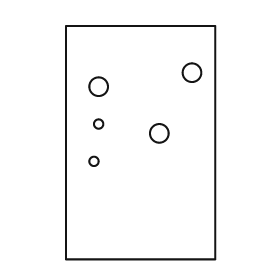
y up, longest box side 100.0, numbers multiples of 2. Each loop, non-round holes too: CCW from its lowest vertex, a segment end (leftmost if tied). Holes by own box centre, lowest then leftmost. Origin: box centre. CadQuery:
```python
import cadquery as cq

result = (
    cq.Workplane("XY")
    .moveTo(-32.0, -50.0)
    .lineTo(32.0, -50.0)
    .lineTo(32.0, 50.0)
    .lineTo(-32.0, 50.0)
    .close()
    .moveTo(-20.0, -8.0)
    .circle(2.0)
    .moveTo(8.0, 4.0)
    .circle(4.0)
    .moveTo(-18.0, 8.0)
    .circle(2.0)
    .moveTo(-18.0, 24.0)
    .circle(4.0)
    .moveTo(22.0, 30.0)
    .circle(4.0)
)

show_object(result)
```